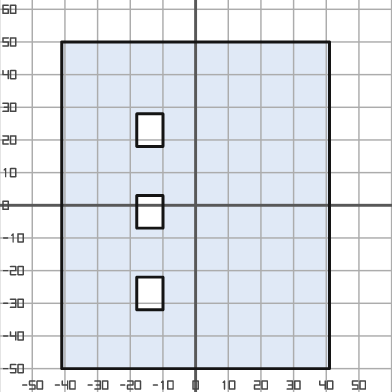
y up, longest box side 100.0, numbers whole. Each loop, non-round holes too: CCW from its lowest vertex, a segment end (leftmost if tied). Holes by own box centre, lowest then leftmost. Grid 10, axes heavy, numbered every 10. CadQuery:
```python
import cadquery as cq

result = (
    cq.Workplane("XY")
    .moveTo(-41.0, -50.0)
    .lineTo(41.0, -50.0)
    .lineTo(41.0, 50.0)
    .lineTo(-41.0, 50.0)
    .close()
    .moveTo(-18.0, -32.0)
    .lineTo(-10.0, -32.0)
    .lineTo(-10.0, -22.0)
    .lineTo(-18.0, -22.0)
    .close()
    .moveTo(-18.0, -7.0)
    .lineTo(-10.0, -7.0)
    .lineTo(-10.0, 3.0)
    .lineTo(-18.0, 3.0)
    .close()
    .moveTo(-18.0, 18.0)
    .lineTo(-10.0, 18.0)
    .lineTo(-10.0, 28.0)
    .lineTo(-18.0, 28.0)
    .close()
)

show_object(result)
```